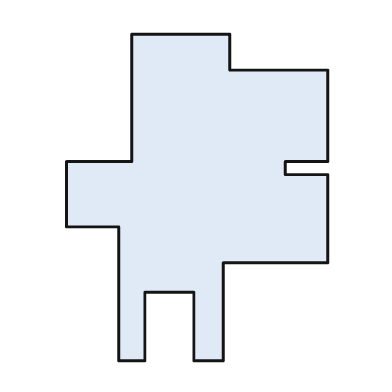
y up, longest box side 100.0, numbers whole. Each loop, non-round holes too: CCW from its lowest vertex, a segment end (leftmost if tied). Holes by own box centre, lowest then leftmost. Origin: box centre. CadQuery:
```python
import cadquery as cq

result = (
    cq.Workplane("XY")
    .moveTo(-24.0, -50.0)
    .lineTo(-16.0, -50.0)
    .lineTo(-16.0, -29.0)
    .lineTo(-1.0, -29.0)
    .lineTo(-1.0, -50.0)
    .lineTo(8.0, -50.0)
    .lineTo(8.0, -20.0)
    .lineTo(40.0, -20.0)
    .lineTo(40.0, 7.0)
    .lineTo(27.0, 7.0)
    .lineTo(27.0, 11.0)
    .lineTo(40.0, 11.0)
    .lineTo(40.0, 39.0)
    .lineTo(10.0, 39.0)
    .lineTo(10.0, 50.0)
    .lineTo(-20.0, 50.0)
    .lineTo(-20.0, 11.0)
    .lineTo(-40.0, 11.0)
    .lineTo(-40.0, -9.0)
    .lineTo(-24.0, -9.0)
    .close()
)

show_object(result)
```